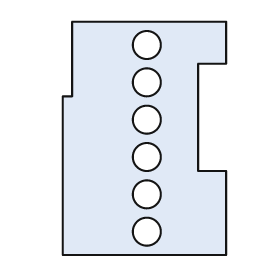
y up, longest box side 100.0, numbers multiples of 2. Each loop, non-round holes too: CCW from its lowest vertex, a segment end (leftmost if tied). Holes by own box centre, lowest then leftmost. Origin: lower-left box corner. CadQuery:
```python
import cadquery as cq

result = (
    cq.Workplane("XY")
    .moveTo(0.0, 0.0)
    .lineTo(70.0, 0.0)
    .lineTo(70.0, 36.0)
    .lineTo(58.0, 36.0)
    .lineTo(58.0, 82.0)
    .lineTo(70.0, 82.0)
    .lineTo(70.0, 100.0)
    .lineTo(4.0, 100.0)
    .lineTo(4.0, 68.0)
    .lineTo(0.0, 68.0)
    .close()
    .moveTo(36.0, 10.0)
    .circle(6.0)
    .moveTo(36.0, 26.0)
    .circle(6.0)
    .moveTo(36.0, 42.0)
    .circle(6.0)
    .moveTo(36.0, 58.0)
    .circle(6.0)
    .moveTo(36.0, 74.0)
    .circle(6.0)
    .moveTo(36.0, 90.0)
    .circle(6.0)
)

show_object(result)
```